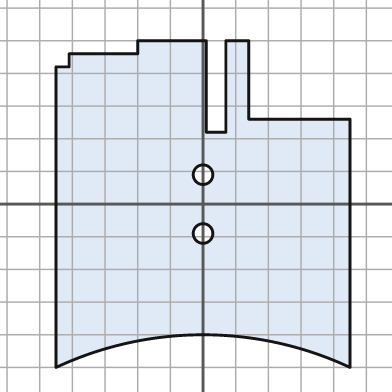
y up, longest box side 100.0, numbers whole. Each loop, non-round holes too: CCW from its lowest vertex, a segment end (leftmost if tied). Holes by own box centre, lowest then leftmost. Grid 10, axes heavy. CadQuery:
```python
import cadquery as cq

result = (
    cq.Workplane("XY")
    .moveTo(-45.0, -50.0)
    .threePointArc((0.0, -40.0), (45.0, -50.0))
    .lineTo(45.0, 26.0)
    .lineTo(14.0, 26.0)
    .lineTo(14.0, 50.0)
    .lineTo(7.0, 50.0)
    .lineTo(7.0, 22.0)
    .lineTo(1.0, 22.0)
    .lineTo(1.0, 50.0)
    .lineTo(-20.0, 50.0)
    .lineTo(-20.0, 46.0)
    .lineTo(-41.0, 46.0)
    .lineTo(-41.0, 42.0)
    .lineTo(-45.0, 42.0)
    .close()
    .moveTo(0.0, -9.0)
    .circle(3.0)
    .moveTo(0.0, 9.0)
    .circle(3.0)
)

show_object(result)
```